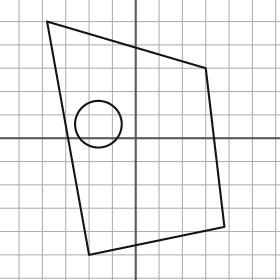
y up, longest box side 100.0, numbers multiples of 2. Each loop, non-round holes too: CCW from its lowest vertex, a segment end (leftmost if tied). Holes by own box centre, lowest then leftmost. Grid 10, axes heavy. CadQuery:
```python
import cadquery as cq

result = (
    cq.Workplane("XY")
    .moveTo(-20.0, -50.0)
    .lineTo(38.0, -38.0)
    .lineTo(30.0, 30.0)
    .lineTo(-38.0, 50.0)
    .close()
    .moveTo(-16.0, 6.0)
    .circle(10.0)
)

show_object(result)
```